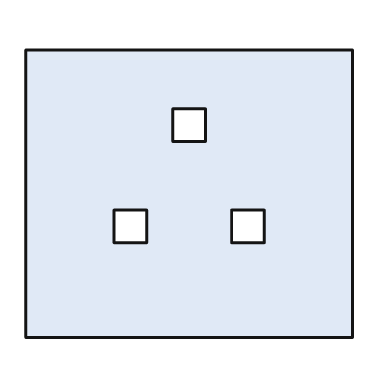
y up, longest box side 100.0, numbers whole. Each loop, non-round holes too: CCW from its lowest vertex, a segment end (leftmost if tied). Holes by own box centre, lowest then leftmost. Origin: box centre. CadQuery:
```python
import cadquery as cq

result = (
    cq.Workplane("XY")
    .moveTo(-50.0, -44.0)
    .lineTo(50.0, -44.0)
    .lineTo(50.0, 44.0)
    .lineTo(-50.0, 44.0)
    .close()
    .moveTo(-23.0, -15.0)
    .lineTo(-13.0, -15.0)
    .lineTo(-13.0, -5.0)
    .lineTo(-23.0, -5.0)
    .close()
    .moveTo(13.0, -15.0)
    .lineTo(23.0, -15.0)
    .lineTo(23.0, -5.0)
    .lineTo(13.0, -5.0)
    .close()
    .moveTo(-5.0, 16.0)
    .lineTo(5.0, 16.0)
    .lineTo(5.0, 26.0)
    .lineTo(-5.0, 26.0)
    .close()
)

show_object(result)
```